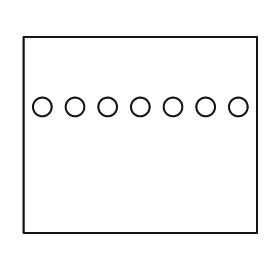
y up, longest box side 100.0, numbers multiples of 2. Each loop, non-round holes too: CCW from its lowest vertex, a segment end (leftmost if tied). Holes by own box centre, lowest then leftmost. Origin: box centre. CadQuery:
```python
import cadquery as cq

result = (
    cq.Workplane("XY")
    .moveTo(-50.0, -42.0)
    .lineTo(50.0, -42.0)
    .lineTo(50.0, 42.0)
    .lineTo(-50.0, 42.0)
    .close()
    .moveTo(-42.0, 12.0)
    .circle(4.0)
    .moveTo(-28.0, 12.0)
    .circle(4.0)
    .moveTo(-14.0, 12.0)
    .circle(4.0)
    .moveTo(0.0, 12.0)
    .circle(4.0)
    .moveTo(14.0, 12.0)
    .circle(4.0)
    .moveTo(28.0, 12.0)
    .circle(4.0)
    .moveTo(42.0, 12.0)
    .circle(4.0)
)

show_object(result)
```